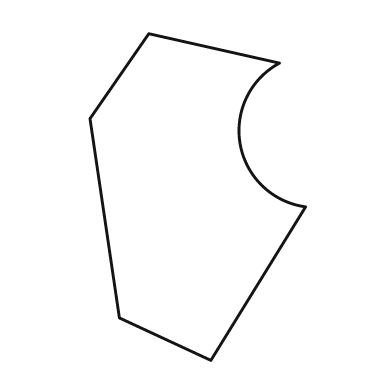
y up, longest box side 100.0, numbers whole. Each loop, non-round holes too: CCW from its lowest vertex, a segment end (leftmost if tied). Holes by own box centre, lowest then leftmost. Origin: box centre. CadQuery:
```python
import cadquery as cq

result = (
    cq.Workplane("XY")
    .moveTo(4.0, -50.0)
    .lineTo(33.0, -3.0)
    .threePointArc((13.0, 16.0), (25.0, 41.0))
    .lineTo(-15.0, 50.0)
    .lineTo(-33.0, 24.0)
    .lineTo(-24.0, -37.0)
    .close()
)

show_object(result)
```